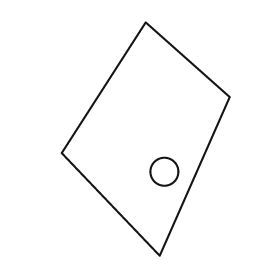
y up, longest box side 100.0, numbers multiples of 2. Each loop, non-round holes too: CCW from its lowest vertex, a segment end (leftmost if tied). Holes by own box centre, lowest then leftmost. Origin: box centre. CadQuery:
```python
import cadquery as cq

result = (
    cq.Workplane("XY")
    .moveTo(6.0, -50.0)
    .lineTo(36.0, 18.0)
    .lineTo(0.0, 50.0)
    .lineTo(-36.0, -6.0)
    .close()
    .moveTo(8.0, -14.0)
    .circle(6.0)
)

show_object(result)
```